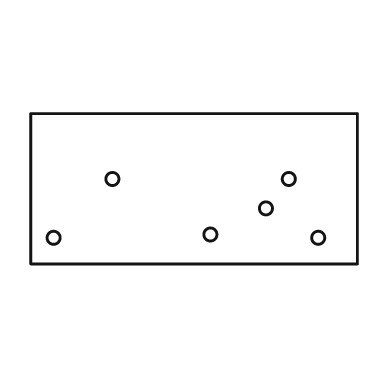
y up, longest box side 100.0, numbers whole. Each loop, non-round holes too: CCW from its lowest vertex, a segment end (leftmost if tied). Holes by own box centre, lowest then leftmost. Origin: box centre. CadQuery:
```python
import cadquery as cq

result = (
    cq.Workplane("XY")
    .moveTo(-50.0, -23.0)
    .lineTo(50.0, -23.0)
    .lineTo(50.0, 23.0)
    .lineTo(-50.0, 23.0)
    .close()
    .moveTo(-43.0, -15.0)
    .circle(2.0)
    .moveTo(38.0, -15.0)
    .circle(2.0)
    .moveTo(5.0, -14.0)
    .circle(2.0)
    .moveTo(22.0, -6.0)
    .circle(2.0)
    .moveTo(-25.0, 3.0)
    .circle(2.0)
    .moveTo(29.0, 3.0)
    .circle(2.0)
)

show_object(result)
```